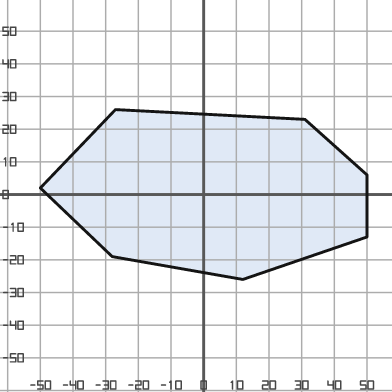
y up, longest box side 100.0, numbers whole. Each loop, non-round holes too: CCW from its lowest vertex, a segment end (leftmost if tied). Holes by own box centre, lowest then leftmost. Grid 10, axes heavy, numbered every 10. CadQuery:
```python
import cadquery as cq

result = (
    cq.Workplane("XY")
    .moveTo(12.0, -26.0)
    .lineTo(50.0, -13.0)
    .lineTo(50.0, 6.0)
    .lineTo(31.0, 23.0)
    .lineTo(-27.0, 26.0)
    .lineTo(-50.0, 2.0)
    .lineTo(-28.0, -19.0)
    .close()
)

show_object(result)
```